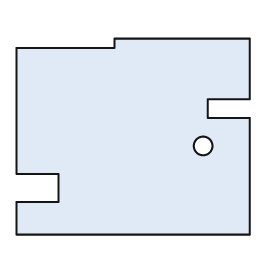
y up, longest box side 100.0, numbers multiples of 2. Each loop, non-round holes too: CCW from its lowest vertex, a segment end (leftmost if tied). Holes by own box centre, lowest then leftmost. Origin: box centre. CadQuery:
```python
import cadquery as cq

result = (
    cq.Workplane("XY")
    .moveTo(-50.0, -42.0)
    .lineTo(50.0, -42.0)
    .lineTo(50.0, 8.0)
    .lineTo(32.0, 8.0)
    .lineTo(32.0, 16.0)
    .lineTo(50.0, 16.0)
    .lineTo(50.0, 42.0)
    .lineTo(-8.0, 42.0)
    .lineTo(-8.0, 38.0)
    .lineTo(-50.0, 38.0)
    .lineTo(-50.0, -16.0)
    .lineTo(-32.0, -16.0)
    .lineTo(-32.0, -28.0)
    .lineTo(-50.0, -28.0)
    .close()
    .moveTo(30.0, -4.0)
    .circle(4.0)
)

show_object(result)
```